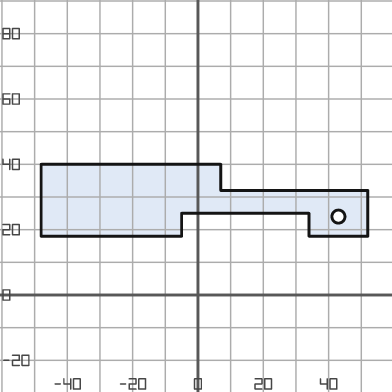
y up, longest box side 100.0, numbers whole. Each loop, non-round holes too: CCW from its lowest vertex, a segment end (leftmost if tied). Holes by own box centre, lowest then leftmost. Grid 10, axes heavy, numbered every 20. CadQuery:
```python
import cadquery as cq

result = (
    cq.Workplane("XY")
    .moveTo(-48.0, 18.0)
    .lineTo(-5.0, 18.0)
    .lineTo(-5.0, 25.0)
    .lineTo(34.0, 25.0)
    .lineTo(34.0, 18.0)
    .lineTo(52.0, 18.0)
    .lineTo(52.0, 32.0)
    .lineTo(7.0, 32.0)
    .lineTo(7.0, 40.0)
    .lineTo(-48.0, 40.0)
    .close()
    .moveTo(43.0, 24.0)
    .circle(2.0)
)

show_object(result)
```